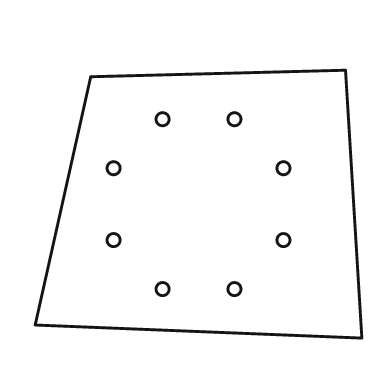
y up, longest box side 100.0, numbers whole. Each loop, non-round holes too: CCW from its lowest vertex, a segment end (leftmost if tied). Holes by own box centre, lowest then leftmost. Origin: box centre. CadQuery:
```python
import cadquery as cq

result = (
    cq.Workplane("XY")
    .moveTo(50.0, -41.0)
    .lineTo(45.0, 41.0)
    .lineTo(-33.0, 39.0)
    .lineTo(-50.0, -37.0)
    .close()
    .moveTo(-11.0, -26.0)
    .circle(2.0)
    .moveTo(11.0, -26.0)
    .circle(2.0)
    .moveTo(-26.0, -11.0)
    .circle(2.0)
    .moveTo(26.0, -11.0)
    .circle(2.0)
    .moveTo(-26.0, 11.0)
    .circle(2.0)
    .moveTo(26.0, 11.0)
    .circle(2.0)
    .moveTo(-11.0, 26.0)
    .circle(2.0)
    .moveTo(11.0, 26.0)
    .circle(2.0)
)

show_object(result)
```